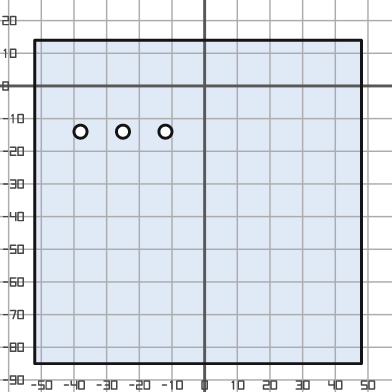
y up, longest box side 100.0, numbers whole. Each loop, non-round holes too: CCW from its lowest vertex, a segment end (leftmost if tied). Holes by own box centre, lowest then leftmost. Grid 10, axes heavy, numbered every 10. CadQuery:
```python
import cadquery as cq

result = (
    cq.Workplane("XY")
    .moveTo(-52.0, -85.0)
    .lineTo(48.0, -85.0)
    .lineTo(48.0, 14.0)
    .lineTo(-52.0, 14.0)
    .close()
    .moveTo(-38.0, -14.0)
    .circle(2.0)
    .moveTo(-25.0, -14.0)
    .circle(2.0)
    .moveTo(-12.0, -14.0)
    .circle(2.0)
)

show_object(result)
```